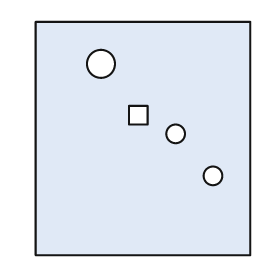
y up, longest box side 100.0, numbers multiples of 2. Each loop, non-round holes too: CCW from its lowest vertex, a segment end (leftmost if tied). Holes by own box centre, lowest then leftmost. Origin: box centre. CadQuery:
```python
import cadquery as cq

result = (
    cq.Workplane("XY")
    .moveTo(-46.0, -50.0)
    .lineTo(46.0, -50.0)
    .lineTo(46.0, 50.0)
    .lineTo(-46.0, 50.0)
    .close()
    .moveTo(30.0, -16.0)
    .circle(4.0)
    .moveTo(14.0, 2.0)
    .circle(4.0)
    .moveTo(-6.0, 6.0)
    .lineTo(2.0, 6.0)
    .lineTo(2.0, 14.0)
    .lineTo(-6.0, 14.0)
    .close()
    .moveTo(-18.0, 32.0)
    .circle(6.0)
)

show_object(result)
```